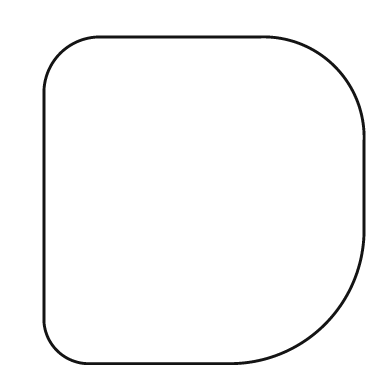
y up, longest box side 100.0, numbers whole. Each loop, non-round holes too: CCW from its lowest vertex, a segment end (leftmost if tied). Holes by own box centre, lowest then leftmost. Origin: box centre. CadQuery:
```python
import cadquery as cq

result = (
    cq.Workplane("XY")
    .moveTo(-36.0, -50.0)
    .lineTo(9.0, -50.0)
    .threePointArc((37.0, -38.0), (49.0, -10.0))
    .lineTo(49.0, 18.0)
    .threePointArc((40.0, 41.0), (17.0, 50.0))
    .lineTo(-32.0, 50.0)
    .threePointArc((-44.0, 45.0), (-49.0, 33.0))
    .lineTo(-49.0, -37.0)
    .threePointArc((-45.0, -46.0), (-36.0, -50.0))
    .close()
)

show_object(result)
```